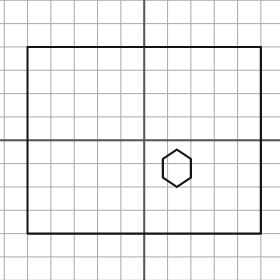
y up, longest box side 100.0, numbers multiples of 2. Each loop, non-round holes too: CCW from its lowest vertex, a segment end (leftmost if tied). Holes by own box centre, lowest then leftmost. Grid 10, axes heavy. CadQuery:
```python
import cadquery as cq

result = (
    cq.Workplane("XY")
    .moveTo(-50.0, -40.0)
    .lineTo(50.0, -40.0)
    .lineTo(50.0, 40.0)
    .lineTo(-50.0, 40.0)
    .close()
    .moveTo(14.0, -20.0)
    .lineTo(20.0, -16.0)
    .lineTo(20.0, -8.0)
    .lineTo(14.0, -4.0)
    .lineTo(8.0, -8.0)
    .lineTo(8.0, -16.0)
    .close()
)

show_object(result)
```